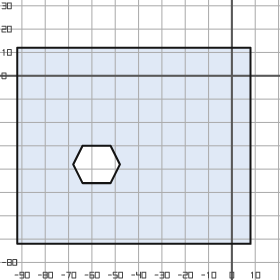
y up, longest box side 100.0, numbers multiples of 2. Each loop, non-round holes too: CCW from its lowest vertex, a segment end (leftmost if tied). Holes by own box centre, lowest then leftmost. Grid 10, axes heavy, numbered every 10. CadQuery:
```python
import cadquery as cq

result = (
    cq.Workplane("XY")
    .moveTo(-92.0, -72.0)
    .lineTo(8.0, -72.0)
    .lineTo(8.0, 12.0)
    .lineTo(-92.0, 12.0)
    .close()
    .moveTo(-64.0, -46.0)
    .lineTo(-52.0, -46.0)
    .lineTo(-48.0, -38.0)
    .lineTo(-52.0, -30.0)
    .lineTo(-64.0, -30.0)
    .lineTo(-68.0, -38.0)
    .close()
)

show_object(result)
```